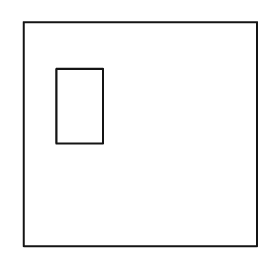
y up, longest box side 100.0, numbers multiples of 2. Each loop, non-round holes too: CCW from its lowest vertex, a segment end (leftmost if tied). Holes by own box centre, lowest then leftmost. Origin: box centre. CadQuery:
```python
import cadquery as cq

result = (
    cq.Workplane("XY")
    .moveTo(-50.0, -48.0)
    .lineTo(50.0, -48.0)
    .lineTo(50.0, 48.0)
    .lineTo(-50.0, 48.0)
    .close()
    .moveTo(-36.0, -4.0)
    .lineTo(-16.0, -4.0)
    .lineTo(-16.0, 28.0)
    .lineTo(-36.0, 28.0)
    .close()
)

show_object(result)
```